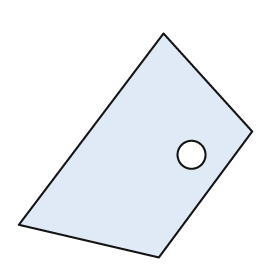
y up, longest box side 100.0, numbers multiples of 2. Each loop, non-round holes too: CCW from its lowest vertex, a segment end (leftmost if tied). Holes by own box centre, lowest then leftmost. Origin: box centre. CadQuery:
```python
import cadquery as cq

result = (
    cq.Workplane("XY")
    .moveTo(10.0, -48.0)
    .lineTo(50.0, 6.0)
    .lineTo(12.0, 48.0)
    .lineTo(-50.0, -34.0)
    .close()
    .moveTo(24.0, -4.0)
    .circle(6.0)
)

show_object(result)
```